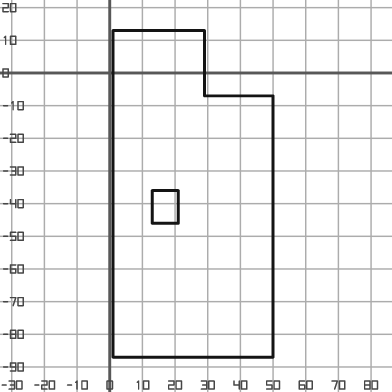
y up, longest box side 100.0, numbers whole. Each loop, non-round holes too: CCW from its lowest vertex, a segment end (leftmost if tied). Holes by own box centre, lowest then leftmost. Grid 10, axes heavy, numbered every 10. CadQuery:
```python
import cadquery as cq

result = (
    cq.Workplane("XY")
    .moveTo(1.0, -87.0)
    .lineTo(50.0, -87.0)
    .lineTo(50.0, -7.0)
    .lineTo(29.0, -7.0)
    .lineTo(29.0, 13.0)
    .lineTo(1.0, 13.0)
    .close()
    .moveTo(13.0, -46.0)
    .lineTo(21.0, -46.0)
    .lineTo(21.0, -36.0)
    .lineTo(13.0, -36.0)
    .close()
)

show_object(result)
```